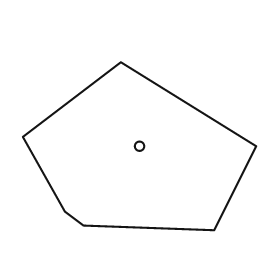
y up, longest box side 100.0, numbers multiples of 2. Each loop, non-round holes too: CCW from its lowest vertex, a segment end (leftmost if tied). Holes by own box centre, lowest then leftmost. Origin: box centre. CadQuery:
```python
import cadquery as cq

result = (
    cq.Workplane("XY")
    .moveTo(32.0, -36.0)
    .lineTo(50.0, 0.0)
    .lineTo(-8.0, 36.0)
    .lineTo(-50.0, 4.0)
    .lineTo(-32.0, -28.0)
    .lineTo(-24.0, -34.0)
    .close()
    .moveTo(0.0, 0.0)
    .circle(2.0)
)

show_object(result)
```